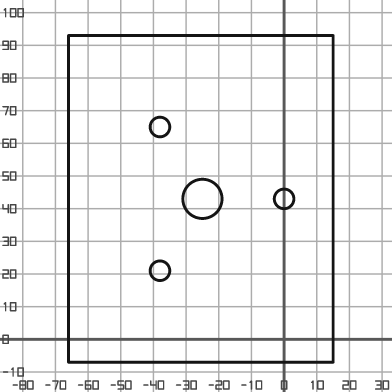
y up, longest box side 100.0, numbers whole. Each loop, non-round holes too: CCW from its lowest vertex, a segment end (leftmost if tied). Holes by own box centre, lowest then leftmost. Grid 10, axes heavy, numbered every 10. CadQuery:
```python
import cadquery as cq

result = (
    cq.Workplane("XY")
    .moveTo(-66.0, -7.0)
    .lineTo(15.0, -7.0)
    .lineTo(15.0, 93.0)
    .lineTo(-66.0, 93.0)
    .close()
    .moveTo(-38.0, 21.0)
    .circle(3.0)
    .moveTo(-25.0, 43.0)
    .circle(6.0)
    .moveTo(0.0, 43.0)
    .circle(3.0)
    .moveTo(-38.0, 65.0)
    .circle(3.0)
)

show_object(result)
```